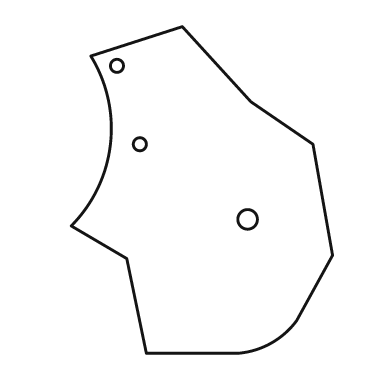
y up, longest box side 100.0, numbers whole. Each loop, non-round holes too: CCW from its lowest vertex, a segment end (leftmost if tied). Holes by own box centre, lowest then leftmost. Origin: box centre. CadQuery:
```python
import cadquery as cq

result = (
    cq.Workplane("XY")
    .moveTo(-17.0, -50.0)
    .lineTo(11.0, -50.0)
    .threePointArc((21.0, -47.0), (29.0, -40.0))
    .lineTo(40.0, -20.0)
    .lineTo(34.0, 14.0)
    .lineTo(15.0, 27.0)
    .lineTo(-6.0, 50.0)
    .lineTo(-34.0, 41.0)
    .threePointArc((-28.0, 14.0), (-40.0, -11.0))
    .lineTo(-23.0, -21.0)
    .close()
    .moveTo(14.0, -9.0)
    .circle(3.0)
    .moveTo(-19.0, 14.0)
    .circle(2.0)
    .moveTo(-26.0, 38.0)
    .circle(2.0)
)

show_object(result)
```